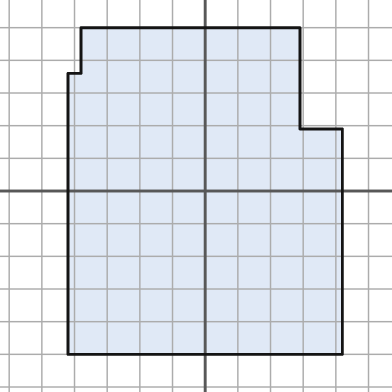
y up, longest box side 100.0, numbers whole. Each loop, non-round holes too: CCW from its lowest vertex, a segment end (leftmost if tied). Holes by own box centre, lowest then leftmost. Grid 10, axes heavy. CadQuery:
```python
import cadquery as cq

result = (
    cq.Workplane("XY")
    .moveTo(-42.0, -50.0)
    .lineTo(42.0, -50.0)
    .lineTo(42.0, 19.0)
    .lineTo(29.0, 19.0)
    .lineTo(29.0, 50.0)
    .lineTo(-38.0, 50.0)
    .lineTo(-38.0, 36.0)
    .lineTo(-42.0, 36.0)
    .close()
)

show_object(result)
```